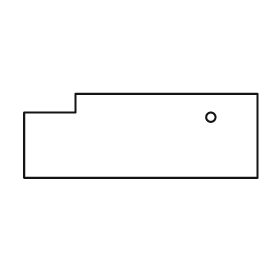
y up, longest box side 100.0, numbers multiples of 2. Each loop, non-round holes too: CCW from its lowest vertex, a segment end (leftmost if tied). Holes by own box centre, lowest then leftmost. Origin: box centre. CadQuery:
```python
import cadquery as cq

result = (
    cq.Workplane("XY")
    .moveTo(-50.0, -18.0)
    .lineTo(50.0, -18.0)
    .lineTo(50.0, 18.0)
    .lineTo(-28.0, 18.0)
    .lineTo(-28.0, 10.0)
    .lineTo(-50.0, 10.0)
    .close()
    .moveTo(30.0, 8.0)
    .circle(2.0)
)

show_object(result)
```